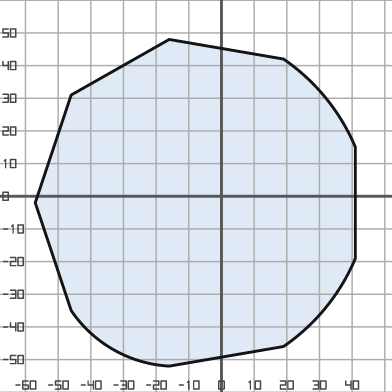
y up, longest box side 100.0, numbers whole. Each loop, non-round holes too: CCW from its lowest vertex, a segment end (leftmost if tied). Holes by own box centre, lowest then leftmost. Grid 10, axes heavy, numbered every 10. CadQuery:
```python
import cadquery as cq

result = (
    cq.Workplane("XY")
    .moveTo(-16.0, -52.0)
    .lineTo(19.0, -46.0)
    .threePointArc((32.0, -34.0), (41.0, -19.0))
    .lineTo(41.0, 15.0)
    .threePointArc((32.0, 30.0), (19.0, 42.0))
    .lineTo(-16.0, 48.0)
    .lineTo(-46.0, 31.0)
    .lineTo(-57.0, -2.0)
    .lineTo(-46.0, -35.0)
    .threePointArc((-33.0, -47.0), (-16.0, -52.0))
    .close()
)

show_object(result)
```